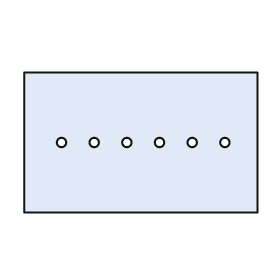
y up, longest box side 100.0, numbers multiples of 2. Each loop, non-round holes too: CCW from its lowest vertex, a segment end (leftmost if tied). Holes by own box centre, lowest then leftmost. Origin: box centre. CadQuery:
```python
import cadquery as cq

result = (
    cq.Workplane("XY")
    .moveTo(-50.0, -30.0)
    .lineTo(50.0, -30.0)
    .lineTo(50.0, 30.0)
    .lineTo(-50.0, 30.0)
    .close()
    .moveTo(-34.0, 0.0)
    .circle(2.0)
    .moveTo(-20.0, 0.0)
    .circle(2.0)
    .moveTo(-6.0, 0.0)
    .circle(2.0)
    .moveTo(8.0, 0.0)
    .circle(2.0)
    .moveTo(22.0, 0.0)
    .circle(2.0)
    .moveTo(36.0, 0.0)
    .circle(2.0)
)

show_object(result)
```